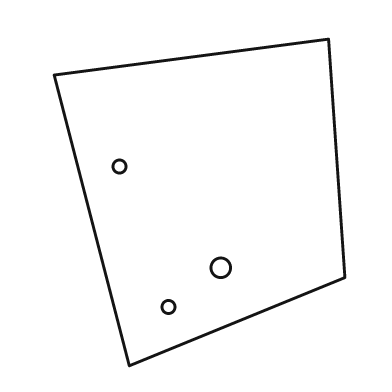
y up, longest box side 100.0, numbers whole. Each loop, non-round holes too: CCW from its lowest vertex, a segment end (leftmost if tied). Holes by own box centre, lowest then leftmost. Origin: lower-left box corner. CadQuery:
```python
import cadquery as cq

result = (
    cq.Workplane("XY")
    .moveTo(23.0, 0.0)
    .lineTo(89.0, 27.0)
    .lineTo(84.0, 100.0)
    .lineTo(0.0, 89.0)
    .close()
    .moveTo(35.0, 18.0)
    .circle(2.0)
    .moveTo(51.0, 30.0)
    .circle(3.0)
    .moveTo(20.0, 61.0)
    .circle(2.0)
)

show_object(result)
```